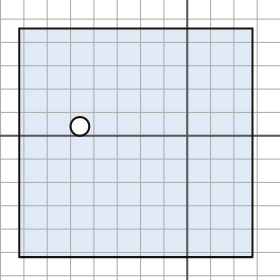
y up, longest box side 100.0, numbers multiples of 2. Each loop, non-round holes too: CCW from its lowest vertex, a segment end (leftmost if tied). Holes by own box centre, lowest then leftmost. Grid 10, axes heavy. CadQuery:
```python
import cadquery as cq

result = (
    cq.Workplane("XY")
    .moveTo(-72.0, -52.0)
    .lineTo(28.0, -52.0)
    .lineTo(28.0, 46.0)
    .lineTo(-72.0, 46.0)
    .close()
    .moveTo(-46.0, 4.0)
    .circle(4.0)
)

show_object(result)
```